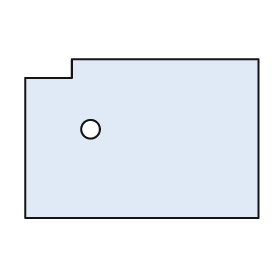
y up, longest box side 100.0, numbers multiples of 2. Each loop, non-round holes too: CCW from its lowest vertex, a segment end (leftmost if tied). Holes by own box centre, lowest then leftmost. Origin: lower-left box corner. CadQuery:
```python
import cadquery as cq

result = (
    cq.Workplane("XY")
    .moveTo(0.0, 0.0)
    .lineTo(100.0, 0.0)
    .lineTo(100.0, 68.0)
    .lineTo(20.0, 68.0)
    .lineTo(20.0, 60.0)
    .lineTo(0.0, 60.0)
    .close()
    .moveTo(28.0, 38.0)
    .circle(4.0)
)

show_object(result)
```